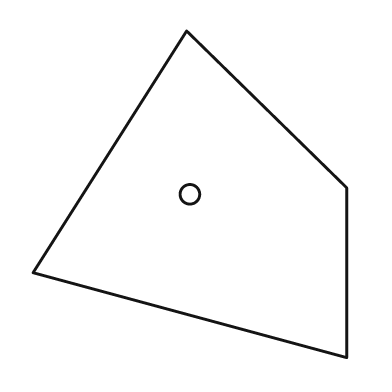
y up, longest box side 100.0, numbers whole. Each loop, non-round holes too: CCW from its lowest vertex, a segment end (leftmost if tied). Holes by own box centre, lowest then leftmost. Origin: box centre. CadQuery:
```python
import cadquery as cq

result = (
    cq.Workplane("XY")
    .moveTo(48.0, -50.0)
    .lineTo(48.0, 2.0)
    .lineTo(-1.0, 50.0)
    .lineTo(-48.0, -24.0)
    .close()
    .moveTo(0.0, 0.0)
    .circle(3.0)
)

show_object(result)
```